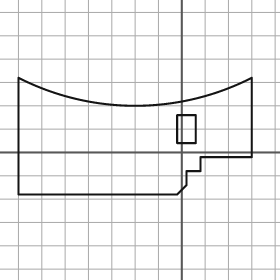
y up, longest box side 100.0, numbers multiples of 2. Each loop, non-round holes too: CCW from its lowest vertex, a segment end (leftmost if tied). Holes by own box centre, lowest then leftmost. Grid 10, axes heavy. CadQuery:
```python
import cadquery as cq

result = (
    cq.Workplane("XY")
    .moveTo(-70.0, -18.0)
    .lineTo(-2.0, -18.0)
    .lineTo(2.0, -14.0)
    .lineTo(2.0, -8.0)
    .lineTo(8.0, -8.0)
    .lineTo(8.0, -2.0)
    .lineTo(30.0, -2.0)
    .lineTo(30.0, 32.0)
    .threePointArc((-20.0, 20.0), (-70.0, 32.0))
    .close()
    .moveTo(-2.0, 4.0)
    .lineTo(6.0, 4.0)
    .lineTo(6.0, 16.0)
    .lineTo(-2.0, 16.0)
    .close()
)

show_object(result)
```